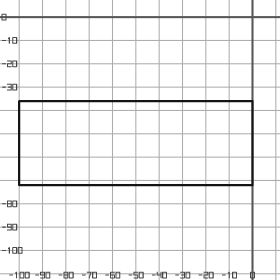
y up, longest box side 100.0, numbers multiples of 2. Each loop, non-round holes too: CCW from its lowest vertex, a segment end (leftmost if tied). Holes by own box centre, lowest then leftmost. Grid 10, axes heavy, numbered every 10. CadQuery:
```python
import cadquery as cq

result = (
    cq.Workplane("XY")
    .moveTo(-100.0, -72.0)
    .lineTo(0.0, -72.0)
    .lineTo(0.0, -36.0)
    .lineTo(-100.0, -36.0)
    .close()
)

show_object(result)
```